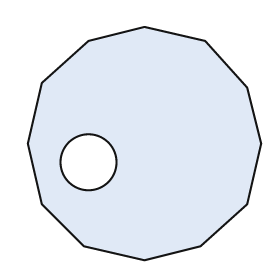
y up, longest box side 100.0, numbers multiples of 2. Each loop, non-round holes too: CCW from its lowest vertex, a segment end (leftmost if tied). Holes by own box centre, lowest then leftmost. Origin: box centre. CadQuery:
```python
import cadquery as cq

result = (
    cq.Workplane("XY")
    .moveTo(0.0, -50.0)
    .lineTo(24.0, -44.0)
    .lineTo(44.0, -26.0)
    .lineTo(50.0, 0.0)
    .lineTo(44.0, 24.0)
    .lineTo(26.0, 44.0)
    .lineTo(0.0, 50.0)
    .lineTo(-24.0, 44.0)
    .lineTo(-44.0, 26.0)
    .lineTo(-50.0, 0.0)
    .lineTo(-44.0, -26.0)
    .lineTo(-26.0, -44.0)
    .close()
    .moveTo(-24.0, -8.0)
    .circle(12.0)
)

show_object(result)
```